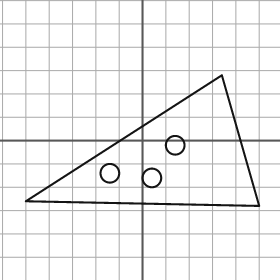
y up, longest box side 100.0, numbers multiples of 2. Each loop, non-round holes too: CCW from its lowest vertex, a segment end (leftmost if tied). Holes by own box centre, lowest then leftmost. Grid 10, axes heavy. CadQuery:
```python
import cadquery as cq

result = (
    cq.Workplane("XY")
    .moveTo(50.0, -28.0)
    .lineTo(34.0, 28.0)
    .lineTo(-50.0, -26.0)
    .close()
    .moveTo(4.0, -16.0)
    .circle(4.0)
    .moveTo(-14.0, -14.0)
    .circle(4.0)
    .moveTo(14.0, -2.0)
    .circle(4.0)
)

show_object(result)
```